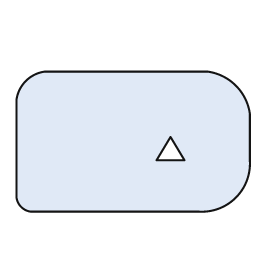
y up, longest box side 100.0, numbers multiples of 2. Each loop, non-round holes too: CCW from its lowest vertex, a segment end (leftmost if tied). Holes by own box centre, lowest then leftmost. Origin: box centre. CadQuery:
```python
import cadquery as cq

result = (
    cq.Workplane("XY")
    .moveTo(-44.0, -30.0)
    .lineTo(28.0, -30.0)
    .threePointArc((44.0, -24.0), (50.0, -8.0))
    .lineTo(50.0, 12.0)
    .threePointArc((44.0, 24.0), (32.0, 30.0))
    .lineTo(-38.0, 30.0)
    .threePointArc((-46.0, 26.0), (-50.0, 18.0))
    .lineTo(-50.0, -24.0)
    .threePointArc((-48.0, -28.0), (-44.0, -30.0))
    .close()
    .moveTo(10.0, -8.0)
    .lineTo(22.0, -8.0)
    .lineTo(16.0, 2.0)
    .close()
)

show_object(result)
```